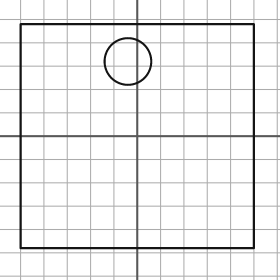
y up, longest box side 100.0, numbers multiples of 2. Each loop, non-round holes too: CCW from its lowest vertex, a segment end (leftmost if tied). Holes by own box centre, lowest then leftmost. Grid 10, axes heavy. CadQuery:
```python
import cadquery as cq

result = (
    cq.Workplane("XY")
    .moveTo(-50.0, -48.0)
    .lineTo(50.0, -48.0)
    .lineTo(50.0, 48.0)
    .lineTo(-50.0, 48.0)
    .close()
    .moveTo(-4.0, 32.0)
    .circle(10.0)
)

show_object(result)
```